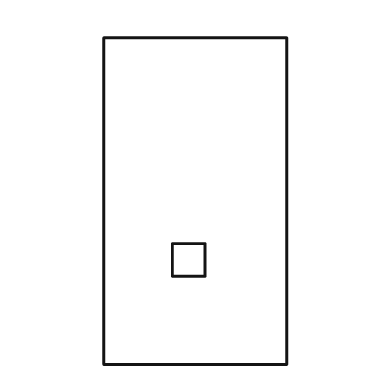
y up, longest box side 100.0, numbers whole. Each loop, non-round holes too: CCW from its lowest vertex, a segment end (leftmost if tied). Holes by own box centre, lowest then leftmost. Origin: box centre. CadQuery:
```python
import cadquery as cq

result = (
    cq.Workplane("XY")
    .moveTo(-28.0, -50.0)
    .lineTo(28.0, -50.0)
    .lineTo(28.0, 50.0)
    .lineTo(-28.0, 50.0)
    .close()
    .moveTo(-7.0, -23.0)
    .lineTo(3.0, -23.0)
    .lineTo(3.0, -13.0)
    .lineTo(-7.0, -13.0)
    .close()
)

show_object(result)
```